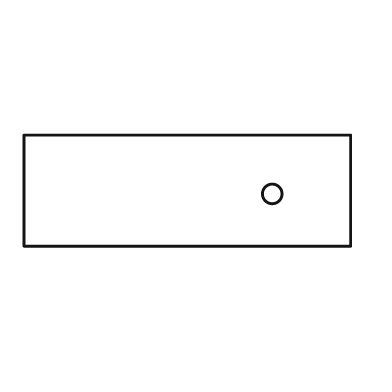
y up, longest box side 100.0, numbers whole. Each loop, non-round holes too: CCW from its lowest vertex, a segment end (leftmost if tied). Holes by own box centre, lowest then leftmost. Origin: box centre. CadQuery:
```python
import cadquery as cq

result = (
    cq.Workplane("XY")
    .moveTo(-50.0, -17.0)
    .lineTo(50.0, -17.0)
    .lineTo(50.0, 17.0)
    .lineTo(-50.0, 17.0)
    .close()
    .moveTo(26.0, -1.0)
    .circle(3.0)
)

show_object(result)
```